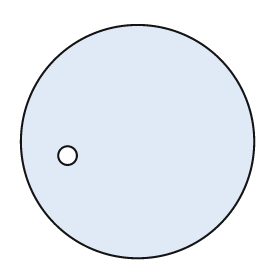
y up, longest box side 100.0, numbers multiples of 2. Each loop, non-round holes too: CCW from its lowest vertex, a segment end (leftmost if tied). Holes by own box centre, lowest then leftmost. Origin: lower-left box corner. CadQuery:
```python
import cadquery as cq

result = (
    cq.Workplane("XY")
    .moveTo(50.0, 50.0)
    .circle(50.0)
    .moveTo(20.0, 44.0)
    .circle(4.0)
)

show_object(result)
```